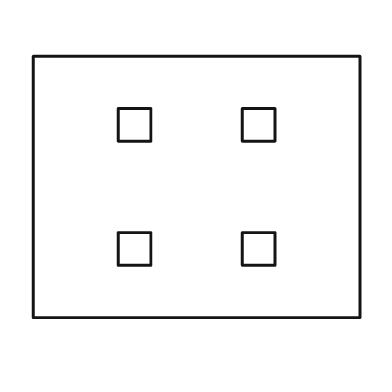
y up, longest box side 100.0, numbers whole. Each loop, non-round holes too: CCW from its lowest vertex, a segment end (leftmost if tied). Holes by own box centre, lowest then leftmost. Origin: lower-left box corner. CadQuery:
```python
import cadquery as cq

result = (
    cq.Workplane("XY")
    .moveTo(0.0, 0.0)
    .lineTo(100.0, 0.0)
    .lineTo(100.0, 80.0)
    .lineTo(0.0, 80.0)
    .close()
    .moveTo(26.0, 16.0)
    .lineTo(36.0, 16.0)
    .lineTo(36.0, 26.0)
    .lineTo(26.0, 26.0)
    .close()
    .moveTo(64.0, 16.0)
    .lineTo(74.0, 16.0)
    .lineTo(74.0, 26.0)
    .lineTo(64.0, 26.0)
    .close()
    .moveTo(26.0, 54.0)
    .lineTo(36.0, 54.0)
    .lineTo(36.0, 64.0)
    .lineTo(26.0, 64.0)
    .close()
    .moveTo(64.0, 54.0)
    .lineTo(74.0, 54.0)
    .lineTo(74.0, 64.0)
    .lineTo(64.0, 64.0)
    .close()
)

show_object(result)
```